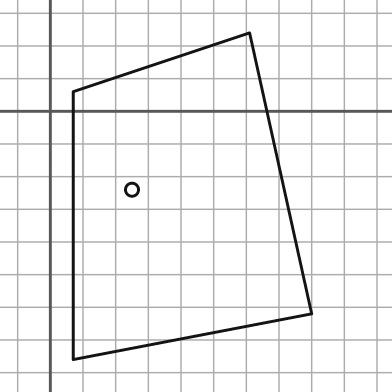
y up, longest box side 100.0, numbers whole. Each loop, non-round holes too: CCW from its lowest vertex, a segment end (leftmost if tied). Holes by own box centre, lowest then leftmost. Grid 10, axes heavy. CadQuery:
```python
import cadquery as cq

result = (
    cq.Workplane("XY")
    .moveTo(7.0, -76.0)
    .lineTo(80.0, -62.0)
    .lineTo(61.0, 24.0)
    .lineTo(7.0, 6.0)
    .close()
    .moveTo(25.0, -24.0)
    .circle(2.0)
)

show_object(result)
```